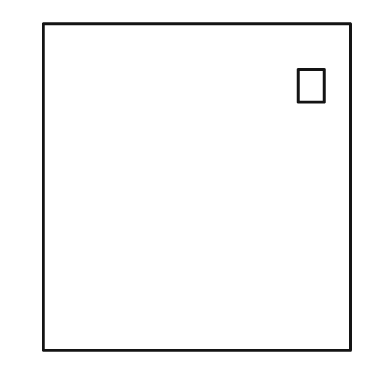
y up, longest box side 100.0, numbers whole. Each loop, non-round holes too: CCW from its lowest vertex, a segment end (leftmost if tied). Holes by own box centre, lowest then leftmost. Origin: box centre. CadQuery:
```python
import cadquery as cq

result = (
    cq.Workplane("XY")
    .moveTo(-47.0, -50.0)
    .lineTo(47.0, -50.0)
    .lineTo(47.0, 50.0)
    .lineTo(-47.0, 50.0)
    .close()
    .moveTo(31.0, 26.0)
    .lineTo(39.0, 26.0)
    .lineTo(39.0, 36.0)
    .lineTo(31.0, 36.0)
    .close()
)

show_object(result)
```